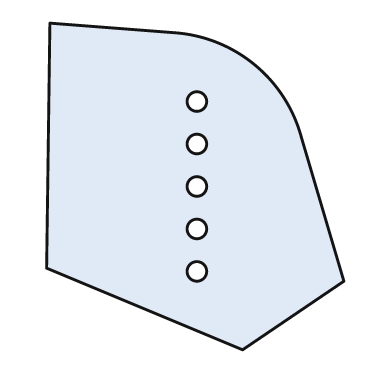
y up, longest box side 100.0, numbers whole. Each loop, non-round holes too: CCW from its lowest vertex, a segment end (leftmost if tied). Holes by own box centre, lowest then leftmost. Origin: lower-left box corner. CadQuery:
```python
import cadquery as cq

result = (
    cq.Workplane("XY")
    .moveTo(60.0, 0.0)
    .lineTo(91.0, 21.0)
    .lineTo(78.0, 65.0)
    .threePointArc((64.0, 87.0), (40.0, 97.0))
    .lineTo(1.0, 100.0)
    .lineTo(0.0, 25.0)
    .close()
    .moveTo(46.0, 24.0)
    .circle(3.0)
    .moveTo(46.0, 37.0)
    .circle(3.0)
    .moveTo(46.0, 50.0)
    .circle(3.0)
    .moveTo(46.0, 63.0)
    .circle(3.0)
    .moveTo(46.0, 76.0)
    .circle(3.0)
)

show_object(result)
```